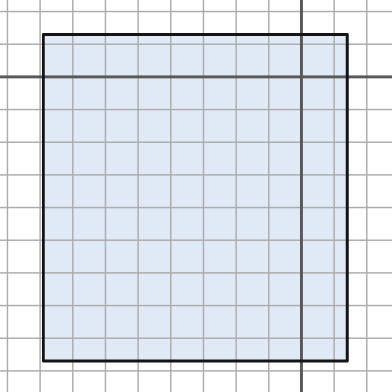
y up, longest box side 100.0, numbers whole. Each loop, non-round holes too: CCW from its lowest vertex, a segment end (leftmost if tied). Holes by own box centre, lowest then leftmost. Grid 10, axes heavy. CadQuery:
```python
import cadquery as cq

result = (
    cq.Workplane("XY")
    .moveTo(-79.0, -87.0)
    .lineTo(14.0, -87.0)
    .lineTo(14.0, 13.0)
    .lineTo(-79.0, 13.0)
    .close()
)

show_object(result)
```